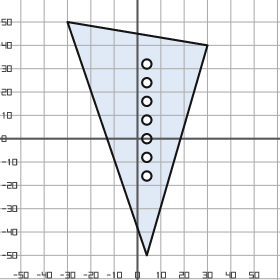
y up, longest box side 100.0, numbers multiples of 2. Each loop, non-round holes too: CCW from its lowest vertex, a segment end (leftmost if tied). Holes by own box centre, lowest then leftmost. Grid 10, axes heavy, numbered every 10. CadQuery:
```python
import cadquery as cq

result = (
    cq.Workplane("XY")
    .moveTo(4.0, -50.0)
    .lineTo(30.0, 40.0)
    .lineTo(-30.0, 50.0)
    .close()
    .moveTo(4.0, -16.0)
    .circle(2.0)
    .moveTo(4.0, -8.0)
    .circle(2.0)
    .moveTo(4.0, 0.0)
    .circle(2.0)
    .moveTo(4.0, 8.0)
    .circle(2.0)
    .moveTo(4.0, 16.0)
    .circle(2.0)
    .moveTo(4.0, 24.0)
    .circle(2.0)
    .moveTo(4.0, 32.0)
    .circle(2.0)
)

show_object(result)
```